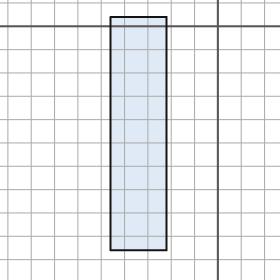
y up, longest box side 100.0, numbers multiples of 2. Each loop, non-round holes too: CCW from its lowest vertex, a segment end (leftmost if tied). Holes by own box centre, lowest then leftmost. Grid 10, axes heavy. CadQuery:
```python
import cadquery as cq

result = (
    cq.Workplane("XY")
    .moveTo(-46.0, -96.0)
    .lineTo(-22.0, -96.0)
    .lineTo(-22.0, 4.0)
    .lineTo(-46.0, 4.0)
    .close()
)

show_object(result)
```